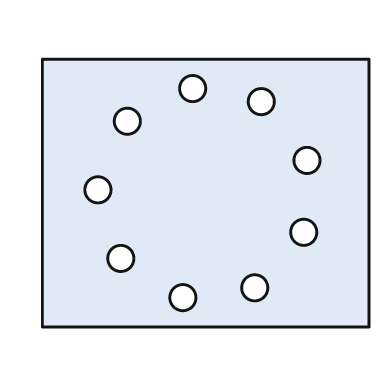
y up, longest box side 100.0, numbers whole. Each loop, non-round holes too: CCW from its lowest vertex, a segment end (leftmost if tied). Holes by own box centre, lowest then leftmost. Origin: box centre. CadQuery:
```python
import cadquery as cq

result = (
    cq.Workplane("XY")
    .moveTo(-50.0, -41.0)
    .lineTo(50.0, -41.0)
    .lineTo(50.0, 41.0)
    .lineTo(-50.0, 41.0)
    .close()
    .moveTo(-7.0, -32.0)
    .circle(4.0)
    .moveTo(15.0, -29.0)
    .circle(4.0)
    .moveTo(-26.0, -20.0)
    .circle(4.0)
    .moveTo(30.0, -12.0)
    .circle(4.0)
    .moveTo(-33.0, 1.0)
    .circle(4.0)
    .moveTo(31.0, 10.0)
    .circle(4.0)
    .moveTo(-24.0, 22.0)
    .circle(4.0)
    .moveTo(17.0, 28.0)
    .circle(4.0)
    .moveTo(-4.0, 32.0)
    .circle(4.0)
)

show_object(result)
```